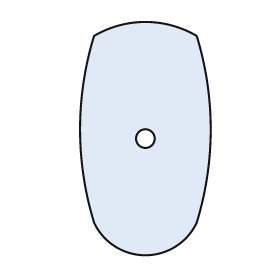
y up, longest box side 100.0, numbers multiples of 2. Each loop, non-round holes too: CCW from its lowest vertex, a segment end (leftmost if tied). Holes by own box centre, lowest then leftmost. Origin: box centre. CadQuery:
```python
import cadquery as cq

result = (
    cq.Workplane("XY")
    .moveTo(-22.0, -36.0)
    .threePointArc((0.0, -50.0), (22.0, -36.0))
    .threePointArc((28.0, 4.0), (22.0, 44.0))
    .threePointArc((0.0, 50.0), (-22.0, 44.0))
    .threePointArc((-28.0, 4.0), (-22.0, -36.0))
    .close()
    .moveTo(0.0, 0.0)
    .circle(4.0)
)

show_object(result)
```